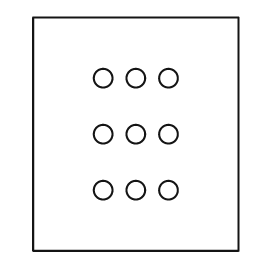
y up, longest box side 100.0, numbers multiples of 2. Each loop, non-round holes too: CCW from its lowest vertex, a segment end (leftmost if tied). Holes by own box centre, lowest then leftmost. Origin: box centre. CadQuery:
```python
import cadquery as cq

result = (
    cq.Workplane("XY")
    .moveTo(-44.0, -50.0)
    .lineTo(44.0, -50.0)
    .lineTo(44.0, 50.0)
    .lineTo(-44.0, 50.0)
    .close()
    .moveTo(-14.0, -24.0)
    .circle(4.0)
    .moveTo(0.0, -24.0)
    .circle(4.0)
    .moveTo(14.0, -24.0)
    .circle(4.0)
    .moveTo(-14.0, 0.0)
    .circle(4.0)
    .moveTo(0.0, 0.0)
    .circle(4.0)
    .moveTo(14.0, 0.0)
    .circle(4.0)
    .moveTo(-14.0, 24.0)
    .circle(4.0)
    .moveTo(0.0, 24.0)
    .circle(4.0)
    .moveTo(14.0, 24.0)
    .circle(4.0)
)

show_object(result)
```